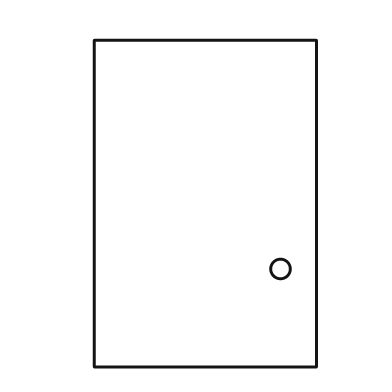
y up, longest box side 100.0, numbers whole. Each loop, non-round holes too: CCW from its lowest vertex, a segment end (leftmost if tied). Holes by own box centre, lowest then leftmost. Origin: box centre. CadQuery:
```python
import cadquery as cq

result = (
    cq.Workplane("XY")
    .moveTo(-34.0, -50.0)
    .lineTo(34.0, -50.0)
    .lineTo(34.0, 50.0)
    .lineTo(-34.0, 50.0)
    .close()
    .moveTo(23.0, -20.0)
    .circle(3.0)
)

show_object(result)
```